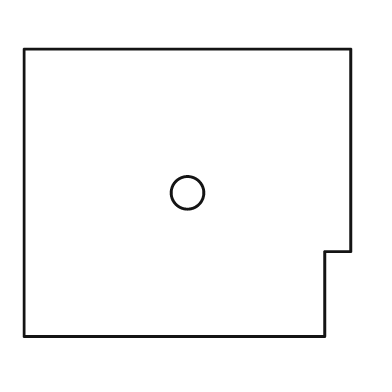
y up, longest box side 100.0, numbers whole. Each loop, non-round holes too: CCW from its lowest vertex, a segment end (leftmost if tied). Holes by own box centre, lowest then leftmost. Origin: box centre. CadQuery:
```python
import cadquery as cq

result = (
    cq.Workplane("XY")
    .moveTo(-50.0, -44.0)
    .lineTo(42.0, -44.0)
    .lineTo(42.0, -18.0)
    .lineTo(50.0, -18.0)
    .lineTo(50.0, 44.0)
    .lineTo(-50.0, 44.0)
    .close()
    .moveTo(0.0, 0.0)
    .circle(5.0)
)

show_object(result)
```